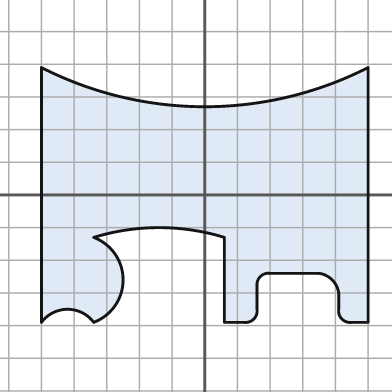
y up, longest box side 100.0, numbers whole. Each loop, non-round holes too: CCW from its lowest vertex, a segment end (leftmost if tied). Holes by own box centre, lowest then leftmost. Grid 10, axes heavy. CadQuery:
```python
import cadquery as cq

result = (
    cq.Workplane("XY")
    .moveTo(-50.0, -39.0)
    .threePointArc((-42.0, -35.0), (-34.0, -39.0))
    .threePointArc((-25.0, -26.0), (-34.0, -13.0))
    .threePointArc((-14.0, -10.0), (6.0, -13.0))
    .lineTo(6.0, -39.0)
    .lineTo(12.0, -39.0)
    .threePointArc((15.0, -38.0), (16.0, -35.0))
    .lineTo(16.0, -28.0)
    .threePointArc((17.0, -25.0), (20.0, -24.0))
    .lineTo(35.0, -24.0)
    .threePointArc((39.0, -26.0), (41.0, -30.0))
    .lineTo(41.0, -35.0)
    .threePointArc((42.0, -38.0), (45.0, -39.0))
    .lineTo(50.0, -39.0)
    .lineTo(50.0, 39.0)
    .threePointArc((0.0, 27.0), (-50.0, 39.0))
    .close()
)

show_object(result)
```